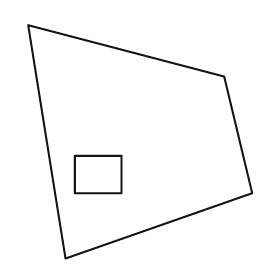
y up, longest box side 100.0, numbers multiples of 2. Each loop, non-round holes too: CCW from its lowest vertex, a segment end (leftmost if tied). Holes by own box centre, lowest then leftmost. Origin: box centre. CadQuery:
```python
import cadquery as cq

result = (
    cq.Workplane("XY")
    .moveTo(-32.0, -50.0)
    .lineTo(48.0, -22.0)
    .lineTo(36.0, 28.0)
    .lineTo(-48.0, 50.0)
    .close()
    .moveTo(-28.0, -22.0)
    .lineTo(-8.0, -22.0)
    .lineTo(-8.0, -6.0)
    .lineTo(-28.0, -6.0)
    .close()
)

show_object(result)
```